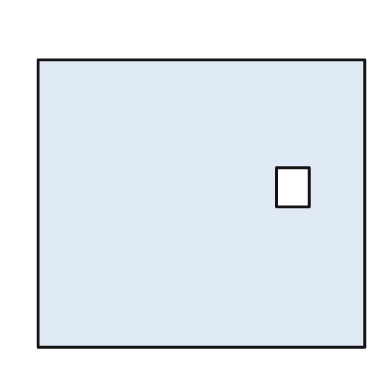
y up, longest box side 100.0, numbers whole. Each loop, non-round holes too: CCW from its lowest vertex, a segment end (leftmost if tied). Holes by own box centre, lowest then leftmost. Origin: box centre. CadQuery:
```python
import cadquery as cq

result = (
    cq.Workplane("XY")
    .moveTo(-50.0, -44.0)
    .lineTo(50.0, -44.0)
    .lineTo(50.0, 44.0)
    .lineTo(-50.0, 44.0)
    .close()
    .moveTo(23.0, -1.0)
    .lineTo(33.0, -1.0)
    .lineTo(33.0, 11.0)
    .lineTo(23.0, 11.0)
    .close()
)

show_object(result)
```